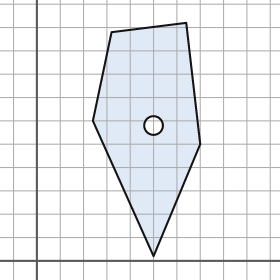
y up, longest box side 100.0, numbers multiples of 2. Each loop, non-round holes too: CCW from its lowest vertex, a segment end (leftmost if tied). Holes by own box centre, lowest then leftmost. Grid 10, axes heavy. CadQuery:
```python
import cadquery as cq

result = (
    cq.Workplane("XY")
    .moveTo(50.0, 2.0)
    .lineTo(70.0, 50.0)
    .lineTo(64.0, 102.0)
    .lineTo(32.0, 98.0)
    .lineTo(24.0, 60.0)
    .close()
    .moveTo(50.0, 58.0)
    .circle(4.0)
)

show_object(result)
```